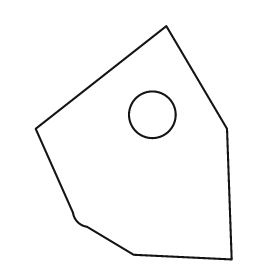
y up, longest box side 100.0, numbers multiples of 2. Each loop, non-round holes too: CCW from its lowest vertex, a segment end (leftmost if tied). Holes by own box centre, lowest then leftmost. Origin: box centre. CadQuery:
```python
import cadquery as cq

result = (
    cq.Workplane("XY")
    .moveTo(42.0, -50.0)
    .lineTo(40.0, 6.0)
    .lineTo(14.0, 50.0)
    .lineTo(-42.0, 6.0)
    .lineTo(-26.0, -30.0)
    .threePointArc((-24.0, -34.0), (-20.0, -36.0))
    .lineTo(0.0, -48.0)
    .close()
    .moveTo(8.0, 12.0)
    .circle(10.0)
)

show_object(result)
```